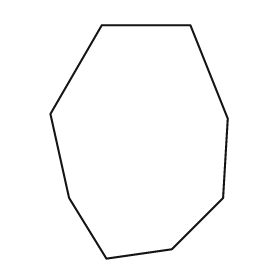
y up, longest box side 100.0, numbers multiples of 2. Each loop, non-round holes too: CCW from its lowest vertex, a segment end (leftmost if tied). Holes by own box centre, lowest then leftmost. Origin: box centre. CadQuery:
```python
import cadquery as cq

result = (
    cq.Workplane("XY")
    .moveTo(-14.0, -50.0)
    .lineTo(14.0, -46.0)
    .lineTo(36.0, -24.0)
    .lineTo(38.0, 10.0)
    .lineTo(22.0, 50.0)
    .lineTo(-16.0, 50.0)
    .lineTo(-38.0, 12.0)
    .lineTo(-30.0, -24.0)
    .close()
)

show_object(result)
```